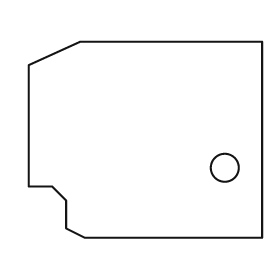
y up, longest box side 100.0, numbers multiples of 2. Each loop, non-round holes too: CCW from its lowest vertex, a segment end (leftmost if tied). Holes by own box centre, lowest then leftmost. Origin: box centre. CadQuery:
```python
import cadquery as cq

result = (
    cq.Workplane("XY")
    .moveTo(-26.0, -42.0)
    .lineTo(50.0, -42.0)
    .lineTo(50.0, 42.0)
    .lineTo(-28.0, 42.0)
    .lineTo(-50.0, 32.0)
    .lineTo(-50.0, -20.0)
    .lineTo(-40.0, -20.0)
    .lineTo(-34.0, -26.0)
    .lineTo(-34.0, -38.0)
    .close()
    .moveTo(34.0, -12.0)
    .circle(6.0)
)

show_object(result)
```